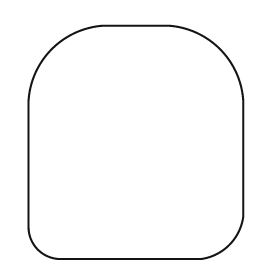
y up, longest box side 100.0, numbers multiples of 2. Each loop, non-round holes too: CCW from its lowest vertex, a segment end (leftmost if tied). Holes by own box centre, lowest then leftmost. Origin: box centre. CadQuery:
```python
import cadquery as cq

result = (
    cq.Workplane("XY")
    .moveTo(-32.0, -50.0)
    .lineTo(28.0, -50.0)
    .threePointArc((40.0, -44.0), (46.0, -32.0))
    .lineTo(46.0, 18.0)
    .threePointArc((36.0, 40.0), (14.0, 50.0))
    .lineTo(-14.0, 50.0)
    .threePointArc((-36.0, 40.0), (-46.0, 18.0))
    .lineTo(-46.0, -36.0)
    .threePointArc((-42.0, -46.0), (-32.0, -50.0))
    .close()
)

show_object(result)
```